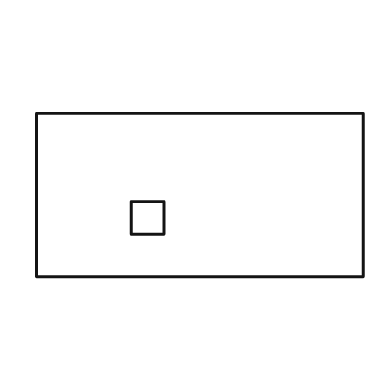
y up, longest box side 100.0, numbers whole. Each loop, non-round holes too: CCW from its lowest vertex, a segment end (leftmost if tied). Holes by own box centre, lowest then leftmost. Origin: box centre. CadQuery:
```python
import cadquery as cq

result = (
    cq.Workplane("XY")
    .moveTo(-50.0, -25.0)
    .lineTo(50.0, -25.0)
    .lineTo(50.0, 25.0)
    .lineTo(-50.0, 25.0)
    .close()
    .moveTo(-21.0, -12.0)
    .lineTo(-11.0, -12.0)
    .lineTo(-11.0, -2.0)
    .lineTo(-21.0, -2.0)
    .close()
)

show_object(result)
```